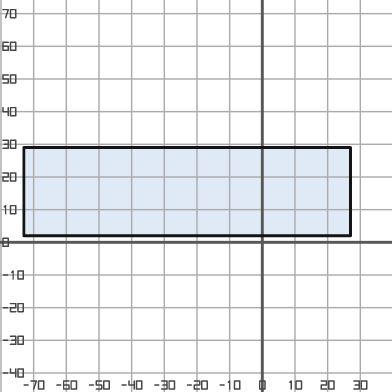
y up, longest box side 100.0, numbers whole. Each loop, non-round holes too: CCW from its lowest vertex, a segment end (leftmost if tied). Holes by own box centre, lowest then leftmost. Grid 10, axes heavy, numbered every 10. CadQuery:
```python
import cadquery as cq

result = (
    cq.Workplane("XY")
    .moveTo(-73.0, 2.0)
    .lineTo(27.0, 2.0)
    .lineTo(27.0, 29.0)
    .lineTo(-73.0, 29.0)
    .close()
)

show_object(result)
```